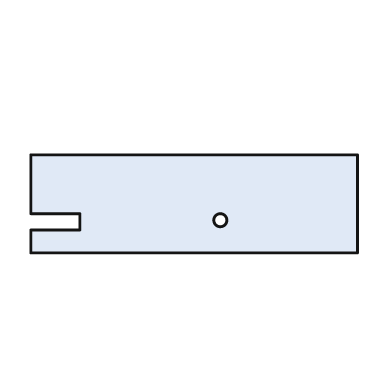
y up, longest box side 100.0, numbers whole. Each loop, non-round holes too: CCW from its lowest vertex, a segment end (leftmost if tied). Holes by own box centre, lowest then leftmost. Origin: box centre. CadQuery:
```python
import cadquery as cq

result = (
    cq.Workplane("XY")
    .moveTo(-50.0, -15.0)
    .lineTo(50.0, -15.0)
    .lineTo(50.0, 15.0)
    .lineTo(-50.0, 15.0)
    .lineTo(-50.0, -3.0)
    .lineTo(-35.0, -3.0)
    .lineTo(-35.0, -8.0)
    .lineTo(-50.0, -8.0)
    .close()
    .moveTo(8.0, -5.0)
    .circle(2.0)
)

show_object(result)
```